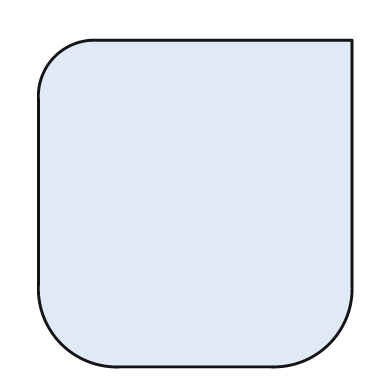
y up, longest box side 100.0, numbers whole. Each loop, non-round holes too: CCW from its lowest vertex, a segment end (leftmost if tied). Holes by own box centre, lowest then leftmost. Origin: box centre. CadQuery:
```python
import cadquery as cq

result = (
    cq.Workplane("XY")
    .moveTo(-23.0, -50.0)
    .lineTo(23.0, -50.0)
    .threePointArc((41.0, -43.0), (48.0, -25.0))
    .lineTo(48.0, 50.0)
    .lineTo(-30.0, 50.0)
    .threePointArc((-43.0, 45.0), (-48.0, 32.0))
    .lineTo(-48.0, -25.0)
    .threePointArc((-41.0, -43.0), (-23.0, -50.0))
    .close()
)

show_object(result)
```